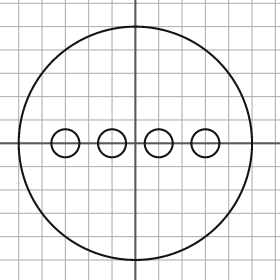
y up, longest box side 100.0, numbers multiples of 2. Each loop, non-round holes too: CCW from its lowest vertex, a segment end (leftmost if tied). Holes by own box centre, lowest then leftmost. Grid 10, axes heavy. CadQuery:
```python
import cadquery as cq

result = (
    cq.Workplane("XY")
    .moveTo(0.0, 0.0)
    .circle(50.0)
    .moveTo(-30.0, 0.0)
    .circle(6.0)
    .moveTo(-10.0, 0.0)
    .circle(6.0)
    .moveTo(10.0, 0.0)
    .circle(6.0)
    .moveTo(30.0, 0.0)
    .circle(6.0)
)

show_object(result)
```